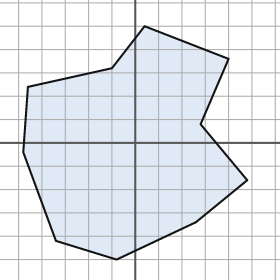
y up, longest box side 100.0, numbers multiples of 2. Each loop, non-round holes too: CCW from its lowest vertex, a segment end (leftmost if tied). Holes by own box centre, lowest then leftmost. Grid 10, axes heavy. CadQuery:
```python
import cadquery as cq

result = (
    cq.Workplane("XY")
    .moveTo(-8.0, -50.0)
    .lineTo(26.0, -34.0)
    .lineTo(48.0, -16.0)
    .lineTo(28.0, 8.0)
    .lineTo(40.0, 36.0)
    .lineTo(4.0, 50.0)
    .lineTo(-10.0, 32.0)
    .lineTo(-46.0, 24.0)
    .lineTo(-48.0, -4.0)
    .lineTo(-34.0, -42.0)
    .close()
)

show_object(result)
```